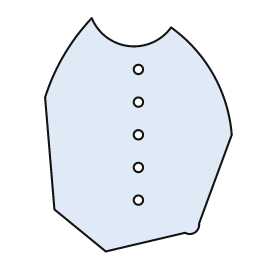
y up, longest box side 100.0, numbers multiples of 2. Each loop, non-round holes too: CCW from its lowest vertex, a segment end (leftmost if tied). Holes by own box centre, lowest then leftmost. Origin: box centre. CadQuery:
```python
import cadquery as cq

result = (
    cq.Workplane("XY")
    .moveTo(-14.0, -50.0)
    .lineTo(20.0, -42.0)
    .threePointArc((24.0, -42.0), (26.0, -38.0))
    .lineTo(40.0, 0.0)
    .threePointArc((32.0, 26.0), (14.0, 46.0))
    .threePointArc((-4.0, 38.0), (-20.0, 50.0))
    .threePointArc((-32.0, 34.0), (-40.0, 16.0))
    .lineTo(-36.0, -32.0)
    .close()
    .moveTo(0.0, -28.0)
    .circle(2.0)
    .moveTo(0.0, -14.0)
    .circle(2.0)
    .moveTo(0.0, 0.0)
    .circle(2.0)
    .moveTo(0.0, 14.0)
    .circle(2.0)
    .moveTo(0.0, 28.0)
    .circle(2.0)
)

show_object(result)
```